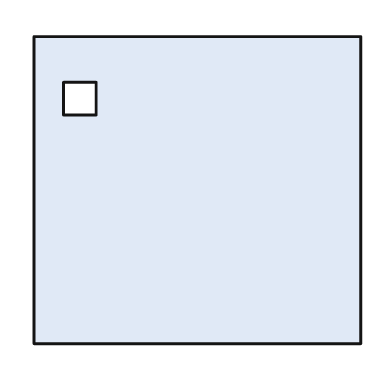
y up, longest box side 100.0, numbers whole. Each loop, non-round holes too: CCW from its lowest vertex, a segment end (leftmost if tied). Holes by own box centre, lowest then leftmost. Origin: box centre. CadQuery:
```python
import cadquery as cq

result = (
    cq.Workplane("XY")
    .moveTo(-50.0, -47.0)
    .lineTo(50.0, -47.0)
    .lineTo(50.0, 47.0)
    .lineTo(-50.0, 47.0)
    .close()
    .moveTo(-41.0, 23.0)
    .lineTo(-31.0, 23.0)
    .lineTo(-31.0, 33.0)
    .lineTo(-41.0, 33.0)
    .close()
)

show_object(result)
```